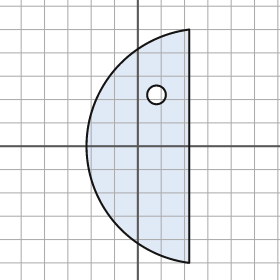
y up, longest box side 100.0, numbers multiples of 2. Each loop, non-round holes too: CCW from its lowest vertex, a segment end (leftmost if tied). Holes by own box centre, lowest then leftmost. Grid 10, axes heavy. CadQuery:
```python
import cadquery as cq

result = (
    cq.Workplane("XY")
    .moveTo(22.0, -50.0)
    .lineTo(22.0, 50.0)
    .threePointArc((-22.0, 0.0), (22.0, -50.0))
    .close()
    .moveTo(8.0, 22.0)
    .circle(4.0)
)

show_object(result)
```